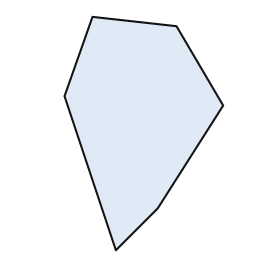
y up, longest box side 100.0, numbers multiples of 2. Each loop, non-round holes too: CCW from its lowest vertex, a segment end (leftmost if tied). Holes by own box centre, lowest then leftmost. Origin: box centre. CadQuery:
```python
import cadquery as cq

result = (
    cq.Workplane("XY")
    .moveTo(-12.0, -50.0)
    .lineTo(6.0, -32.0)
    .lineTo(34.0, 12.0)
    .lineTo(14.0, 46.0)
    .lineTo(-22.0, 50.0)
    .lineTo(-34.0, 16.0)
    .close()
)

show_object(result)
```